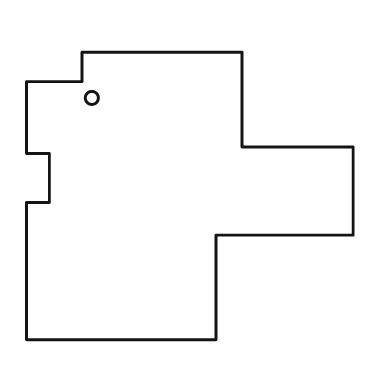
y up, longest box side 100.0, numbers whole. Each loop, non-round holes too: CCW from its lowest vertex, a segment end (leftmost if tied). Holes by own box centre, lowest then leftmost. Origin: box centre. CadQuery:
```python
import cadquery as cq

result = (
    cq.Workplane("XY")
    .moveTo(-50.0, -44.0)
    .lineTo(8.0, -44.0)
    .lineTo(8.0, -12.0)
    .lineTo(50.0, -12.0)
    .lineTo(50.0, 15.0)
    .lineTo(16.0, 15.0)
    .lineTo(16.0, 44.0)
    .lineTo(-33.0, 44.0)
    .lineTo(-33.0, 35.0)
    .lineTo(-50.0, 35.0)
    .lineTo(-50.0, 13.0)
    .lineTo(-43.0, 13.0)
    .lineTo(-43.0, -2.0)
    .lineTo(-50.0, -2.0)
    .close()
    .moveTo(-30.0, 30.0)
    .circle(2.0)
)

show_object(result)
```